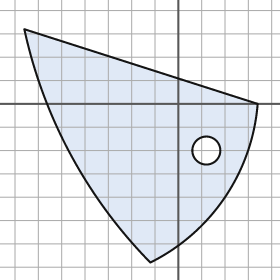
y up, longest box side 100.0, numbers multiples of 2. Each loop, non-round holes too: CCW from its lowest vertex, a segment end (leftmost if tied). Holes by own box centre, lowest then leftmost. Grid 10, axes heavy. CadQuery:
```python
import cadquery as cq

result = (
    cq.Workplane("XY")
    .moveTo(-12.0, -68.0)
    .threePointArc((20.0, -40.0), (34.0, 0.0))
    .lineTo(-66.0, 32.0)
    .threePointArc((-46.0, -22.0), (-12.0, -68.0))
    .close()
    .moveTo(12.0, -20.0)
    .circle(6.0)
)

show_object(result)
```